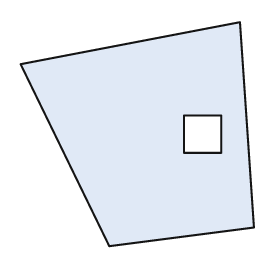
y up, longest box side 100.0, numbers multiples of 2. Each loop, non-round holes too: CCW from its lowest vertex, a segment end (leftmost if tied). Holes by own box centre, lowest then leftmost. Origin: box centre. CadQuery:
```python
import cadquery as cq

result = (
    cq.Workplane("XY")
    .moveTo(-12.0, -48.0)
    .lineTo(50.0, -40.0)
    .lineTo(44.0, 48.0)
    .lineTo(-50.0, 30.0)
    .close()
    .moveTo(20.0, -8.0)
    .lineTo(36.0, -8.0)
    .lineTo(36.0, 8.0)
    .lineTo(20.0, 8.0)
    .close()
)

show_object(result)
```